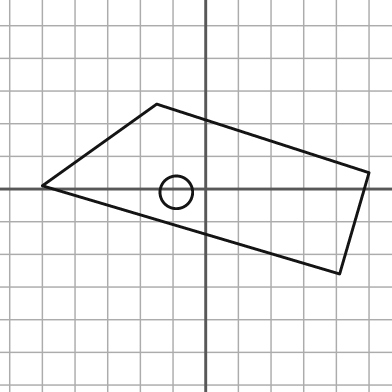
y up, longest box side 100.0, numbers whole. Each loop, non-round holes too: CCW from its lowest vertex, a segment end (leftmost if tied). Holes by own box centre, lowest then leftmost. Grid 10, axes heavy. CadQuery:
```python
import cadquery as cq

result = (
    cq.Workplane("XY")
    .moveTo(41.0, -26.0)
    .lineTo(50.0, 5.0)
    .lineTo(-15.0, 26.0)
    .lineTo(-50.0, 1.0)
    .close()
    .moveTo(-9.0, -1.0)
    .circle(5.0)
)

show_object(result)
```